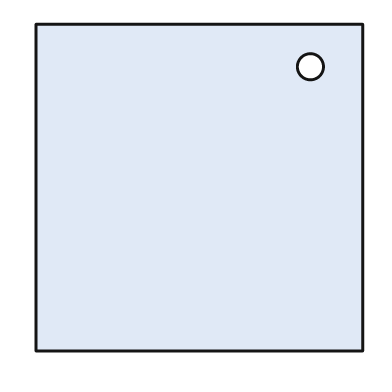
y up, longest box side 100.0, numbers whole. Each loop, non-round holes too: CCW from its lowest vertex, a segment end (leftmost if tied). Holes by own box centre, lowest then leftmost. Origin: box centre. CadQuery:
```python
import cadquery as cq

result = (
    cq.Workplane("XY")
    .moveTo(-50.0, -50.0)
    .lineTo(50.0, -50.0)
    .lineTo(50.0, 50.0)
    .lineTo(-50.0, 50.0)
    .close()
    .moveTo(34.0, 37.0)
    .circle(4.0)
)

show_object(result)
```